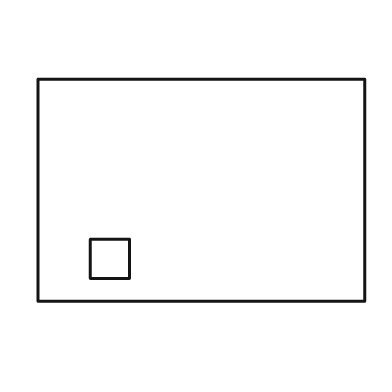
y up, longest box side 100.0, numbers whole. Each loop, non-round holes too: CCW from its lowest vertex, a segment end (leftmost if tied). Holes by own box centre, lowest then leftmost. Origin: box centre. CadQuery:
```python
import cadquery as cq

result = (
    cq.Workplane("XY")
    .moveTo(-50.0, -34.0)
    .lineTo(50.0, -34.0)
    .lineTo(50.0, 34.0)
    .lineTo(-50.0, 34.0)
    .close()
    .moveTo(-34.0, -27.0)
    .lineTo(-22.0, -27.0)
    .lineTo(-22.0, -15.0)
    .lineTo(-34.0, -15.0)
    .close()
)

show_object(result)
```